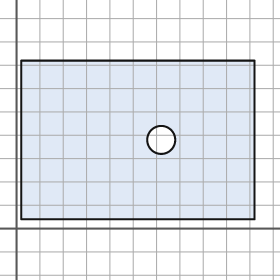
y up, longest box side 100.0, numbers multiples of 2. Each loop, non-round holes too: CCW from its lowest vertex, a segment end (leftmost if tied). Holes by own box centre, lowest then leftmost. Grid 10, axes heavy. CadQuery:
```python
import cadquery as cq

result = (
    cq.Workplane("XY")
    .moveTo(2.0, 4.0)
    .lineTo(102.0, 4.0)
    .lineTo(102.0, 72.0)
    .lineTo(2.0, 72.0)
    .close()
    .moveTo(62.0, 38.0)
    .circle(6.0)
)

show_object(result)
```